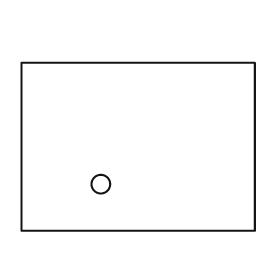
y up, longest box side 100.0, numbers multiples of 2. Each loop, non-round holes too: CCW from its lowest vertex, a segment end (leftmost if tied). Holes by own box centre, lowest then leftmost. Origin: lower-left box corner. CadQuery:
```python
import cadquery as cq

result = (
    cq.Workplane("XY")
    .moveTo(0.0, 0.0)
    .lineTo(100.0, 0.0)
    .lineTo(100.0, 72.0)
    .lineTo(0.0, 72.0)
    .close()
    .moveTo(34.0, 20.0)
    .circle(4.0)
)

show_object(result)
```